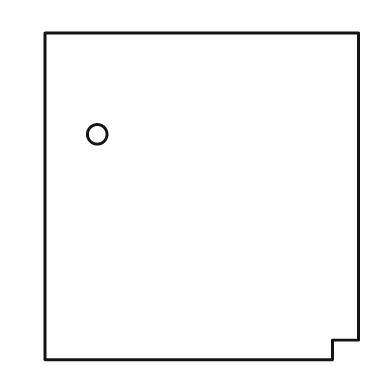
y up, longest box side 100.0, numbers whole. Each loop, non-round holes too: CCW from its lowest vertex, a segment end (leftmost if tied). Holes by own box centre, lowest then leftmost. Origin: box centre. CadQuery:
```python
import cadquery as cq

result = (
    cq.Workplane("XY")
    .moveTo(-48.0, -50.0)
    .lineTo(40.0, -50.0)
    .lineTo(40.0, -44.0)
    .lineTo(48.0, -44.0)
    .lineTo(48.0, 50.0)
    .lineTo(-48.0, 50.0)
    .close()
    .moveTo(-32.0, 19.0)
    .circle(3.0)
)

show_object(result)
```